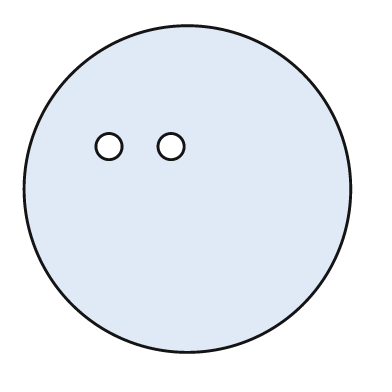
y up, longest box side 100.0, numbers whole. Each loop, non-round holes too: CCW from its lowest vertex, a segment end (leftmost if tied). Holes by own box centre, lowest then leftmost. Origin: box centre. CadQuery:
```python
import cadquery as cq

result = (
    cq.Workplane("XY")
    .moveTo(0.0, 0.0)
    .circle(50.0)
    .moveTo(-24.0, 13.0)
    .circle(4.0)
    .moveTo(-5.0, 13.0)
    .circle(4.0)
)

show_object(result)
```